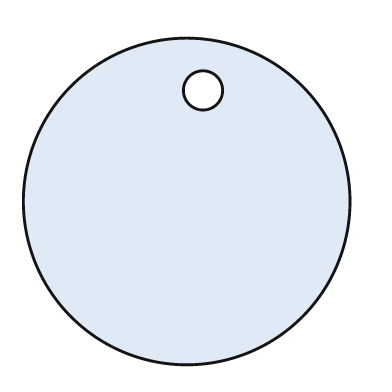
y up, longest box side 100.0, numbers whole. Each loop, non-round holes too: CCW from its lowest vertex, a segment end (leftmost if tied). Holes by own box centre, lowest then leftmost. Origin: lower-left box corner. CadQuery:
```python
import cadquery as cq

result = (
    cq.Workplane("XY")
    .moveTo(50.0, 50.0)
    .circle(50.0)
    .moveTo(55.0, 84.0)
    .circle(6.0)
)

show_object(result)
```